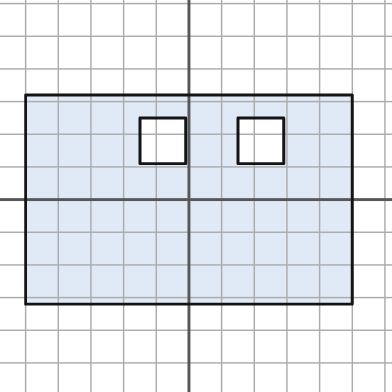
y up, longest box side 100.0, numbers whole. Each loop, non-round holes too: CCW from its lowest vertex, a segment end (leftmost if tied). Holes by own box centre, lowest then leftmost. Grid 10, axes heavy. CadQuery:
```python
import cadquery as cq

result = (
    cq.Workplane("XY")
    .moveTo(-50.0, -32.0)
    .lineTo(50.0, -32.0)
    .lineTo(50.0, 32.0)
    .lineTo(-50.0, 32.0)
    .close()
    .moveTo(-15.0, 11.0)
    .lineTo(-1.0, 11.0)
    .lineTo(-1.0, 25.0)
    .lineTo(-15.0, 25.0)
    .close()
    .moveTo(15.0, 11.0)
    .lineTo(29.0, 11.0)
    .lineTo(29.0, 25.0)
    .lineTo(15.0, 25.0)
    .close()
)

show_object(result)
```